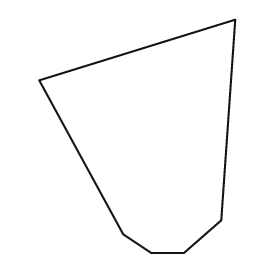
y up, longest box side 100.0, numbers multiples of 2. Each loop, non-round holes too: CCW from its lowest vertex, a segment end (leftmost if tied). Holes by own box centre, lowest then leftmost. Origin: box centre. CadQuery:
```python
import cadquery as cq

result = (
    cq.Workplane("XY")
    .moveTo(6.0, -50.0)
    .lineTo(20.0, -50.0)
    .lineTo(36.0, -36.0)
    .lineTo(42.0, 50.0)
    .lineTo(-42.0, 24.0)
    .lineTo(-6.0, -42.0)
    .close()
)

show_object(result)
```